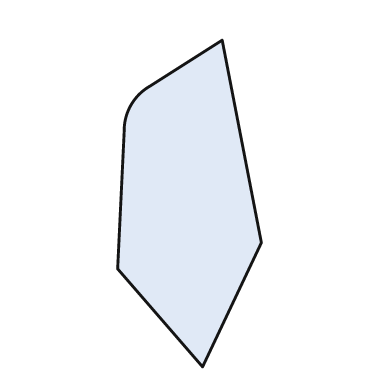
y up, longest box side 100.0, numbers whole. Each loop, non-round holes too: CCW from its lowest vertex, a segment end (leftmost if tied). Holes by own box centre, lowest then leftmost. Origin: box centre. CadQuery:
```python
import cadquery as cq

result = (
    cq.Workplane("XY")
    .moveTo(4.0, -50.0)
    .lineTo(22.0, -12.0)
    .lineTo(10.0, 50.0)
    .lineTo(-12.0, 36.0)
    .threePointArc((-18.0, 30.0), (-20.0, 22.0))
    .lineTo(-22.0, -20.0)
    .close()
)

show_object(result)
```